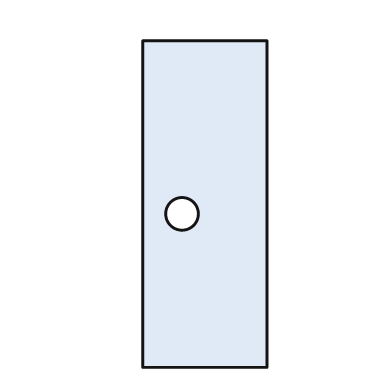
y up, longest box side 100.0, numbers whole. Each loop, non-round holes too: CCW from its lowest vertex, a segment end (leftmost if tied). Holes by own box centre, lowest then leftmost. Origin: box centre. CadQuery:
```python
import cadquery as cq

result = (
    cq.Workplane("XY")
    .moveTo(-19.0, -50.0)
    .lineTo(19.0, -50.0)
    .lineTo(19.0, 50.0)
    .lineTo(-19.0, 50.0)
    .close()
    .moveTo(-7.0, -3.0)
    .circle(5.0)
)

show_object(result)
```